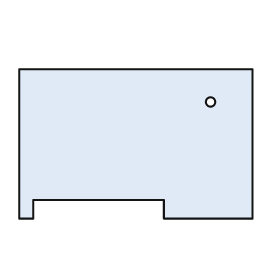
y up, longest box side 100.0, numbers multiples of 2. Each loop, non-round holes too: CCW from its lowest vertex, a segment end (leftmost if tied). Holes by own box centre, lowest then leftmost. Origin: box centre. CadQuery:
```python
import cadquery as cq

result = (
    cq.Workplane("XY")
    .moveTo(-50.0, -32.0)
    .lineTo(-44.0, -32.0)
    .lineTo(-44.0, -24.0)
    .lineTo(12.0, -24.0)
    .lineTo(12.0, -32.0)
    .lineTo(50.0, -32.0)
    .lineTo(50.0, 32.0)
    .lineTo(-50.0, 32.0)
    .close()
    .moveTo(32.0, 18.0)
    .circle(2.0)
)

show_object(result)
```